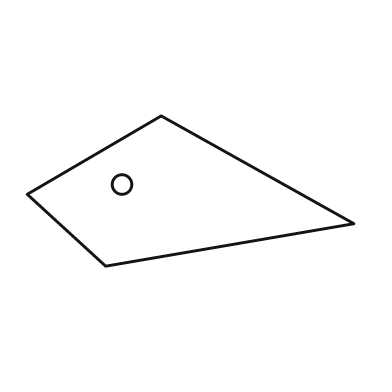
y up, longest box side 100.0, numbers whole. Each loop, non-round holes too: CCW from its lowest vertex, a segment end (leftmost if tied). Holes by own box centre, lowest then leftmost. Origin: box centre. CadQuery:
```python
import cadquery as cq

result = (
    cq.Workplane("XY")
    .moveTo(-26.0, -23.0)
    .lineTo(50.0, -10.0)
    .lineTo(-9.0, 23.0)
    .lineTo(-50.0, -1.0)
    .close()
    .moveTo(-21.0, 2.0)
    .circle(3.0)
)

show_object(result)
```